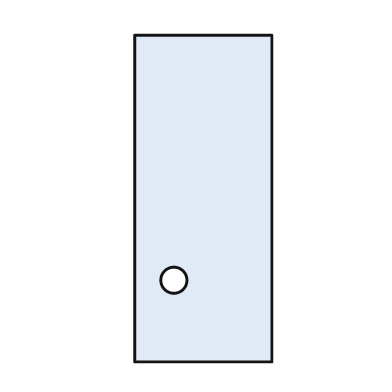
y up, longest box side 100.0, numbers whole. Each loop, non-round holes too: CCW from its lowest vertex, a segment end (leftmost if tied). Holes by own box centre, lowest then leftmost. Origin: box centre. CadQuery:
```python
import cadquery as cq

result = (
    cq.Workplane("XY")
    .moveTo(-21.0, -50.0)
    .lineTo(21.0, -50.0)
    .lineTo(21.0, 50.0)
    .lineTo(-21.0, 50.0)
    .close()
    .moveTo(-9.0, -25.0)
    .circle(4.0)
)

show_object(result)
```